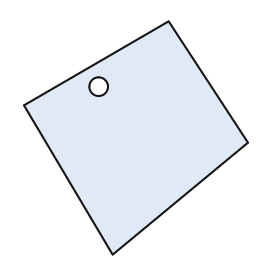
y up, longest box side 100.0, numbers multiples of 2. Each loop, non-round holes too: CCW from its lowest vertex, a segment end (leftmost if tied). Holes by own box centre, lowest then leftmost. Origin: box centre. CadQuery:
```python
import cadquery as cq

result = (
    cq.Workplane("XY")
    .moveTo(-10.0, -50.0)
    .lineTo(48.0, -2.0)
    .lineTo(14.0, 50.0)
    .lineTo(-48.0, 14.0)
    .close()
    .moveTo(-16.0, 22.0)
    .circle(4.0)
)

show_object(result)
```